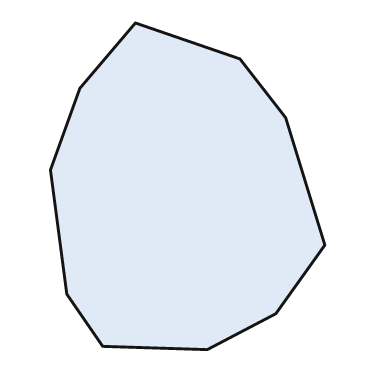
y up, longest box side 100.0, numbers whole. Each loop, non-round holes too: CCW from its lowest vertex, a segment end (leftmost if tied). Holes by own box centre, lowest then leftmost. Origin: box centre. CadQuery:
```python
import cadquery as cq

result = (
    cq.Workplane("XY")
    .moveTo(6.0, -50.0)
    .lineTo(27.0, -39.0)
    .lineTo(42.0, -18.0)
    .lineTo(30.0, 21.0)
    .lineTo(16.0, 39.0)
    .lineTo(-16.0, 50.0)
    .lineTo(-33.0, 30.0)
    .lineTo(-42.0, 5.0)
    .lineTo(-37.0, -33.0)
    .lineTo(-26.0, -49.0)
    .close()
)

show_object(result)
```